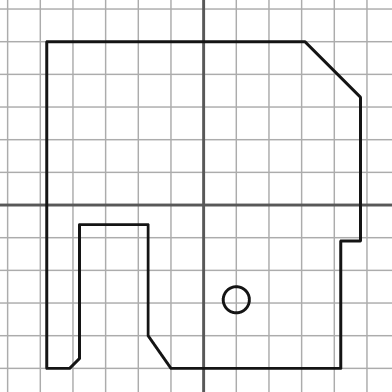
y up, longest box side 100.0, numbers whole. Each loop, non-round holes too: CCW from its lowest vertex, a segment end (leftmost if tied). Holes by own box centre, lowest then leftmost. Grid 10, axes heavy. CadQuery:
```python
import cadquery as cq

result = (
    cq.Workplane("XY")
    .moveTo(-48.0, -50.0)
    .lineTo(-41.0, -50.0)
    .lineTo(-38.0, -47.0)
    .lineTo(-38.0, -6.0)
    .lineTo(-17.0, -6.0)
    .lineTo(-17.0, -40.0)
    .lineTo(-10.0, -50.0)
    .lineTo(42.0, -50.0)
    .lineTo(42.0, -11.0)
    .lineTo(48.0, -11.0)
    .lineTo(48.0, 33.0)
    .lineTo(31.0, 50.0)
    .lineTo(-48.0, 50.0)
    .close()
    .moveTo(10.0, -29.0)
    .circle(4.0)
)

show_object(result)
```